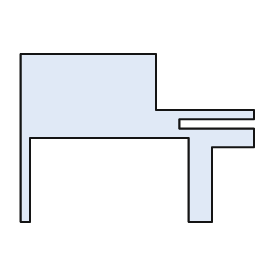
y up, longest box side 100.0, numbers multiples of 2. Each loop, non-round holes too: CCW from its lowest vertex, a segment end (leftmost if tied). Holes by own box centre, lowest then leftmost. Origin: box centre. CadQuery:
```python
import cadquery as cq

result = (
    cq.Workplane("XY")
    .moveTo(-50.0, -36.0)
    .lineTo(-46.0, -36.0)
    .lineTo(-46.0, 0.0)
    .lineTo(22.0, 0.0)
    .lineTo(22.0, -36.0)
    .lineTo(32.0, -36.0)
    .lineTo(32.0, -4.0)
    .lineTo(50.0, -4.0)
    .lineTo(50.0, 4.0)
    .lineTo(18.0, 4.0)
    .lineTo(18.0, 8.0)
    .lineTo(50.0, 8.0)
    .lineTo(50.0, 12.0)
    .lineTo(8.0, 12.0)
    .lineTo(8.0, 36.0)
    .lineTo(-50.0, 36.0)
    .close()
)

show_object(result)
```